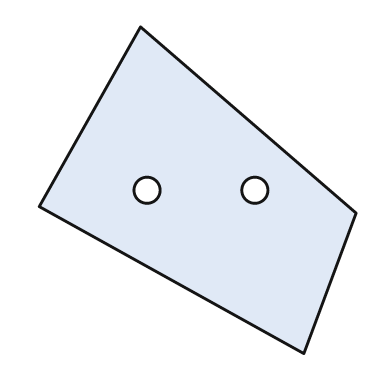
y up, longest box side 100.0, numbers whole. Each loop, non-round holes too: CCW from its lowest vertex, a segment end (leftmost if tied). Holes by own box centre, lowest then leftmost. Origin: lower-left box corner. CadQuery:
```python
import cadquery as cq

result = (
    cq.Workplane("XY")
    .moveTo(81.0, 0.0)
    .lineTo(97.0, 43.0)
    .lineTo(31.0, 100.0)
    .lineTo(0.0, 45.0)
    .close()
    .moveTo(33.0, 50.0)
    .circle(4.0)
    .moveTo(66.0, 50.0)
    .circle(4.0)
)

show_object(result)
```